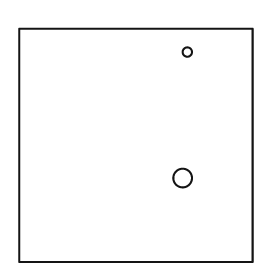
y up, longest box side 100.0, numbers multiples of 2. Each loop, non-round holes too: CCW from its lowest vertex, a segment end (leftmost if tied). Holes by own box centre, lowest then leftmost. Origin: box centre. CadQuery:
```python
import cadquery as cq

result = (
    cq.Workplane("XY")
    .moveTo(-50.0, -50.0)
    .lineTo(50.0, -50.0)
    .lineTo(50.0, 50.0)
    .lineTo(-50.0, 50.0)
    .close()
    .moveTo(20.0, -14.0)
    .circle(4.0)
    .moveTo(22.0, 40.0)
    .circle(2.0)
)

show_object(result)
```